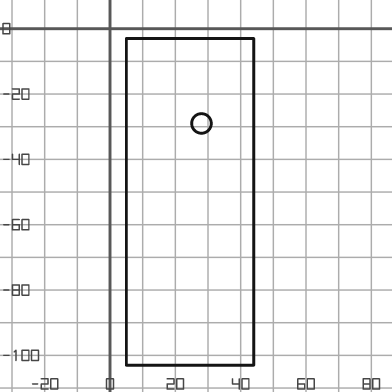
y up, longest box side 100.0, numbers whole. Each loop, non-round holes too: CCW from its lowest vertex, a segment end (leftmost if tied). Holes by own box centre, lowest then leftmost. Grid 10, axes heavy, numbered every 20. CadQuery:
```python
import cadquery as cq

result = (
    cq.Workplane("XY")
    .moveTo(5.0, -103.0)
    .lineTo(44.0, -103.0)
    .lineTo(44.0, -3.0)
    .lineTo(5.0, -3.0)
    .close()
    .moveTo(28.0, -29.0)
    .circle(3.0)
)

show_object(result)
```